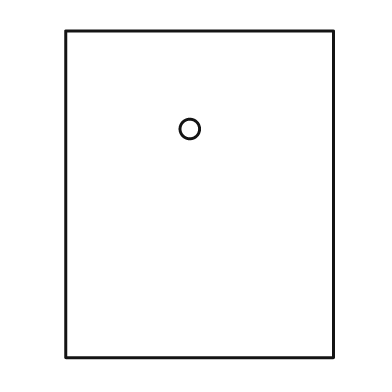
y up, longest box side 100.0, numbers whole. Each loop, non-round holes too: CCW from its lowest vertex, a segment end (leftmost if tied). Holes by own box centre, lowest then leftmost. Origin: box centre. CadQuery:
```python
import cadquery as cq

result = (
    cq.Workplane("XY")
    .moveTo(-41.0, -50.0)
    .lineTo(41.0, -50.0)
    .lineTo(41.0, 50.0)
    .lineTo(-41.0, 50.0)
    .close()
    .moveTo(-3.0, 20.0)
    .circle(3.0)
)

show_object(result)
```